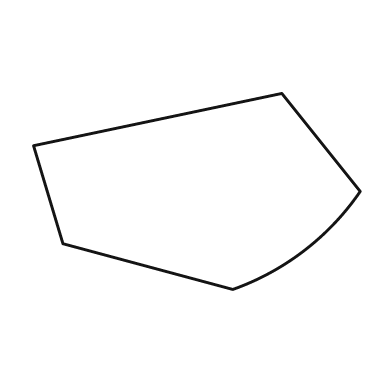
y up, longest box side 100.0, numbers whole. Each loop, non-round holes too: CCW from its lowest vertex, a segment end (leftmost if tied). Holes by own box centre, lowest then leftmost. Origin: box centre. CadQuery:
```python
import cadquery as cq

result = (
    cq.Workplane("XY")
    .moveTo(11.0, -30.0)
    .threePointArc((33.0, -18.0), (50.0, 0.0))
    .lineTo(26.0, 30.0)
    .lineTo(-50.0, 14.0)
    .lineTo(-41.0, -16.0)
    .close()
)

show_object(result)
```